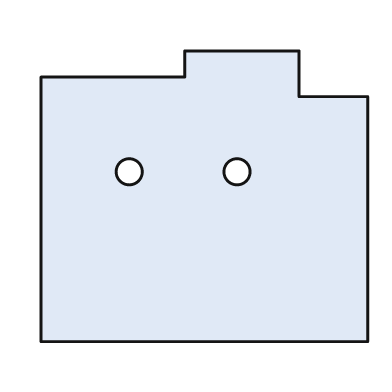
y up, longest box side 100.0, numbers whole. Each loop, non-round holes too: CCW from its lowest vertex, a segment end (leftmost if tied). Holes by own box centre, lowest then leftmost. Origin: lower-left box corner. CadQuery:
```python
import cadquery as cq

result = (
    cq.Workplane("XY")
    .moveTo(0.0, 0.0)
    .lineTo(100.0, 0.0)
    .lineTo(100.0, 75.0)
    .lineTo(79.0, 75.0)
    .lineTo(79.0, 89.0)
    .lineTo(44.0, 89.0)
    .lineTo(44.0, 81.0)
    .lineTo(0.0, 81.0)
    .close()
    .moveTo(27.0, 52.0)
    .circle(4.0)
    .moveTo(60.0, 52.0)
    .circle(4.0)
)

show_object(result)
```